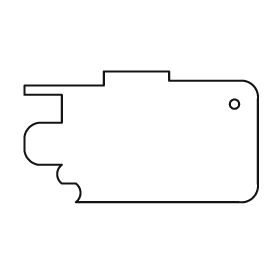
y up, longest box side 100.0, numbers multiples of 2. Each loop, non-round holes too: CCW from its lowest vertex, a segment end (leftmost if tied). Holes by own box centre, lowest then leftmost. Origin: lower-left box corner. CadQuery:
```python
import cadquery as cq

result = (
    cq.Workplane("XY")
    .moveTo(22.0, 0.0)
    .lineTo(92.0, 0.0)
    .threePointArc((98.0, 2.0), (100.0, 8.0))
    .lineTo(100.0, 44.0)
    .threePointArc((98.0, 50.0), (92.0, 52.0))
    .lineTo(62.0, 52.0)
    .lineTo(62.0, 56.0)
    .lineTo(34.0, 56.0)
    .lineTo(34.0, 50.0)
    .lineTo(0.0, 50.0)
    .lineTo(0.0, 46.0)
    .lineTo(16.0, 46.0)
    .lineTo(16.0, 34.0)
    .lineTo(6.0, 34.0)
    .threePointArc((2.0, 32.0), (0.0, 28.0))
    .lineTo(0.0, 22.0)
    .threePointArc((2.0, 18.0), (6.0, 16.0))
    .lineTo(16.0, 16.0)
    .threePointArc((14.0, 12.0), (16.0, 8.0))
    .lineTo(22.0, 8.0)
    .threePointArc((24.0, 4.0), (22.0, 0.0))
    .close()
    .moveTo(90.0, 42.0)
    .circle(2.0)
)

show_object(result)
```